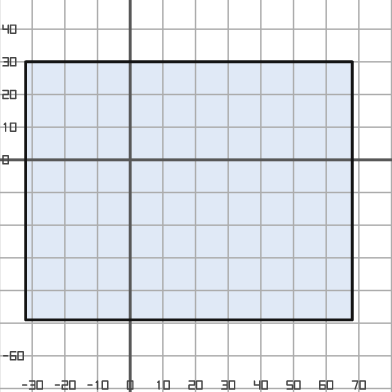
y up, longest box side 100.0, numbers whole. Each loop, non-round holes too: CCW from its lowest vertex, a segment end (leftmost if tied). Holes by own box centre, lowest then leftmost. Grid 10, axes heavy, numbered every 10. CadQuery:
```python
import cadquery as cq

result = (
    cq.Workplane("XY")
    .moveTo(-32.0, -49.0)
    .lineTo(68.0, -49.0)
    .lineTo(68.0, 30.0)
    .lineTo(-32.0, 30.0)
    .close()
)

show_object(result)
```